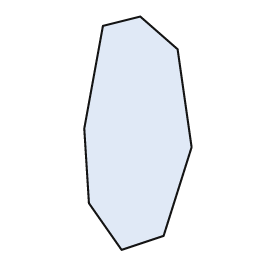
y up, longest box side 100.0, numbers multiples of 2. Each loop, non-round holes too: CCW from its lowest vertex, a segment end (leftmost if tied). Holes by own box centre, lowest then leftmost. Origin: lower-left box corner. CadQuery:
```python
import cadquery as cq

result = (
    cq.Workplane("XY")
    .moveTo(16.0, 0.0)
    .lineTo(34.0, 6.0)
    .lineTo(46.0, 44.0)
    .lineTo(40.0, 86.0)
    .lineTo(24.0, 100.0)
    .lineTo(8.0, 96.0)
    .lineTo(0.0, 52.0)
    .lineTo(2.0, 20.0)
    .close()
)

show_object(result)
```